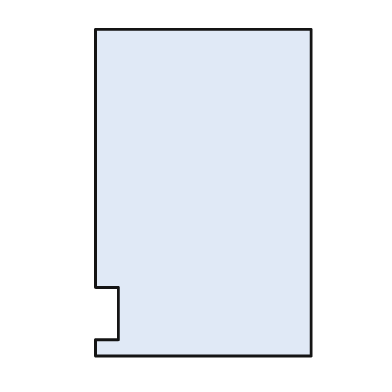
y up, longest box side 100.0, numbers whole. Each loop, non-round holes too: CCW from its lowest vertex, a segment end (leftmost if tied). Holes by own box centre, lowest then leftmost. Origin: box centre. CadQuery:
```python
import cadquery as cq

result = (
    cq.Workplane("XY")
    .moveTo(-33.0, -50.0)
    .lineTo(33.0, -50.0)
    .lineTo(33.0, 50.0)
    .lineTo(-33.0, 50.0)
    .lineTo(-33.0, -29.0)
    .lineTo(-26.0, -29.0)
    .lineTo(-26.0, -45.0)
    .lineTo(-33.0, -45.0)
    .close()
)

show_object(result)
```